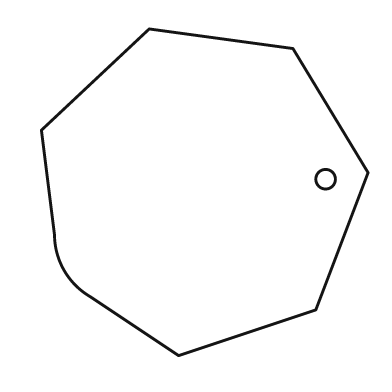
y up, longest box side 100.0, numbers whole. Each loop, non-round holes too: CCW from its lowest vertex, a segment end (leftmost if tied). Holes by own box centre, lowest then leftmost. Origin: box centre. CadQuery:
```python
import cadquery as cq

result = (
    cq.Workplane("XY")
    .moveTo(-8.0, -50.0)
    .lineTo(34.0, -36.0)
    .lineTo(50.0, 6.0)
    .lineTo(27.0, 44.0)
    .lineTo(-17.0, 50.0)
    .lineTo(-50.0, 19.0)
    .lineTo(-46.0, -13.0)
    .threePointArc((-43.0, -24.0), (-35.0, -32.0))
    .close()
    .moveTo(37.0, 4.0)
    .circle(3.0)
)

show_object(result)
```